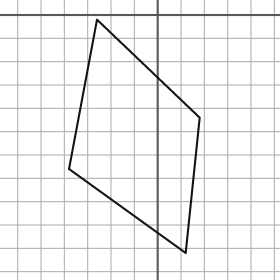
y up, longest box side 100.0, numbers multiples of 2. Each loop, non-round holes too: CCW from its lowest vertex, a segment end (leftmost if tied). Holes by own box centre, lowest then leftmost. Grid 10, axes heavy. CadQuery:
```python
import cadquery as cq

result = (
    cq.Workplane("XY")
    .moveTo(12.0, -102.0)
    .lineTo(18.0, -44.0)
    .lineTo(-26.0, -2.0)
    .lineTo(-38.0, -66.0)
    .close()
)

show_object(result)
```